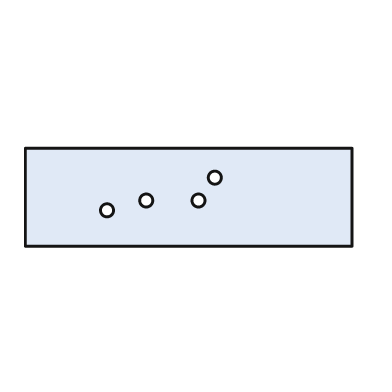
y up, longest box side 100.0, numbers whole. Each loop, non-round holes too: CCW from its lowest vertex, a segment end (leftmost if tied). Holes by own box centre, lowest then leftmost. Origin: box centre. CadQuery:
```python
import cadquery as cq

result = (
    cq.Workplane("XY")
    .moveTo(-50.0, -15.0)
    .lineTo(50.0, -15.0)
    .lineTo(50.0, 15.0)
    .lineTo(-50.0, 15.0)
    .close()
    .moveTo(-25.0, -4.0)
    .circle(2.0)
    .moveTo(-13.0, -1.0)
    .circle(2.0)
    .moveTo(3.0, -1.0)
    .circle(2.0)
    .moveTo(8.0, 6.0)
    .circle(2.0)
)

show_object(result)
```